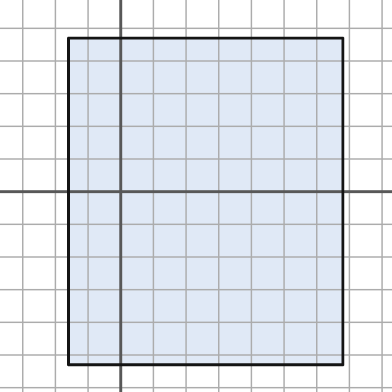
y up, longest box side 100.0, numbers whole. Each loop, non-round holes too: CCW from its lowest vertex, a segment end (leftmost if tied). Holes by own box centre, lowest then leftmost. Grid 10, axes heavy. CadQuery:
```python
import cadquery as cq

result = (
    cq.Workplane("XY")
    .moveTo(-16.0, -53.0)
    .lineTo(68.0, -53.0)
    .lineTo(68.0, 47.0)
    .lineTo(-16.0, 47.0)
    .close()
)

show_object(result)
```